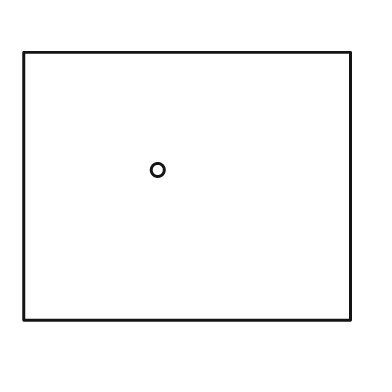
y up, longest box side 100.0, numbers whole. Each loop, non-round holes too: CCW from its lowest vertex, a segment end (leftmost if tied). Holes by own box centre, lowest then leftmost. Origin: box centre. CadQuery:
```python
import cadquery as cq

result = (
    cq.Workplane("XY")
    .moveTo(-50.0, -41.0)
    .lineTo(50.0, -41.0)
    .lineTo(50.0, 41.0)
    .lineTo(-50.0, 41.0)
    .close()
    .moveTo(-9.0, 5.0)
    .circle(2.0)
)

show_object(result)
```